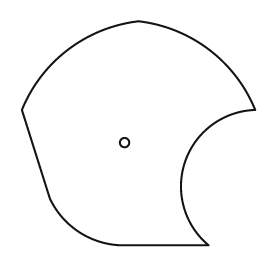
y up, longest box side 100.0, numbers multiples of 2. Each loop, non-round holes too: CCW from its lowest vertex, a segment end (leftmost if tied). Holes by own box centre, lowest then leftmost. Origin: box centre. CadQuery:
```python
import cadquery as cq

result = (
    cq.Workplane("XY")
    .moveTo(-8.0, -48.0)
    .lineTo(30.0, -48.0)
    .threePointArc((20.0, -12.0), (50.0, 10.0))
    .threePointArc((30.0, 36.0), (0.0, 48.0))
    .threePointArc((-30.0, 36.0), (-50.0, 10.0))
    .lineTo(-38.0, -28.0)
    .threePointArc((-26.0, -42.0), (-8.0, -48.0))
    .close()
    .moveTo(-6.0, -4.0)
    .circle(2.0)
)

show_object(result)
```